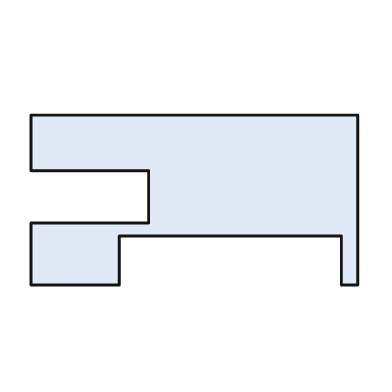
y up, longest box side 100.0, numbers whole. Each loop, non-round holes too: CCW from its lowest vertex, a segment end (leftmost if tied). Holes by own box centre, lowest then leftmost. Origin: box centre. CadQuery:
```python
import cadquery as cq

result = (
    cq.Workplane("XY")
    .moveTo(-50.0, -26.0)
    .lineTo(-23.0, -26.0)
    .lineTo(-23.0, -11.0)
    .lineTo(45.0, -11.0)
    .lineTo(45.0, -26.0)
    .lineTo(50.0, -26.0)
    .lineTo(50.0, 26.0)
    .lineTo(-50.0, 26.0)
    .lineTo(-50.0, 9.0)
    .lineTo(-14.0, 9.0)
    .lineTo(-14.0, -7.0)
    .lineTo(-50.0, -7.0)
    .close()
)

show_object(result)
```